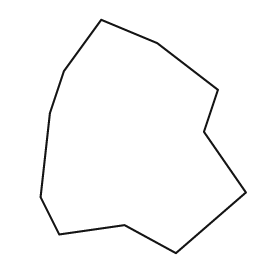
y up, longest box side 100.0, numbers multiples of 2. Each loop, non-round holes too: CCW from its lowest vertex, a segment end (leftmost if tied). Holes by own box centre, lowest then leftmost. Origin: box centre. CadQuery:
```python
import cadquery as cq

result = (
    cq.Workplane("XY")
    .moveTo(14.0, -50.0)
    .lineTo(44.0, -24.0)
    .lineTo(26.0, 2.0)
    .lineTo(32.0, 20.0)
    .lineTo(6.0, 40.0)
    .lineTo(-18.0, 50.0)
    .lineTo(-34.0, 28.0)
    .lineTo(-40.0, 10.0)
    .lineTo(-44.0, -26.0)
    .lineTo(-36.0, -42.0)
    .lineTo(-8.0, -38.0)
    .close()
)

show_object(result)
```